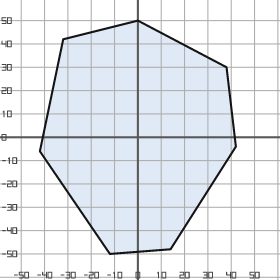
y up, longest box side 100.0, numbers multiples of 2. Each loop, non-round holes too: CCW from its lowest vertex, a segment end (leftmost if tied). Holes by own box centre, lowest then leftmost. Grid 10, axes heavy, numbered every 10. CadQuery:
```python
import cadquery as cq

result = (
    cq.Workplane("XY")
    .moveTo(-12.0, -50.0)
    .lineTo(14.0, -48.0)
    .lineTo(42.0, -4.0)
    .lineTo(38.0, 30.0)
    .lineTo(0.0, 50.0)
    .lineTo(-32.0, 42.0)
    .lineTo(-42.0, -6.0)
    .close()
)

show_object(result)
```